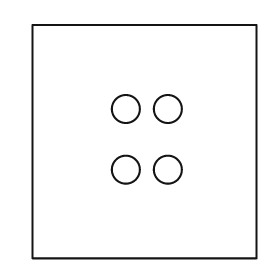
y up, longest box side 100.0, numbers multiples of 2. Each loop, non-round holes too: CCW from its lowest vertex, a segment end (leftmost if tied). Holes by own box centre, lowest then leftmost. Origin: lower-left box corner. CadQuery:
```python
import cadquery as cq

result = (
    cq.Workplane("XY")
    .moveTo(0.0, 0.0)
    .lineTo(96.0, 0.0)
    .lineTo(96.0, 100.0)
    .lineTo(0.0, 100.0)
    .close()
    .moveTo(40.0, 38.0)
    .circle(6.0)
    .moveTo(58.0, 38.0)
    .circle(6.0)
    .moveTo(40.0, 64.0)
    .circle(6.0)
    .moveTo(58.0, 64.0)
    .circle(6.0)
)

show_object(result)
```